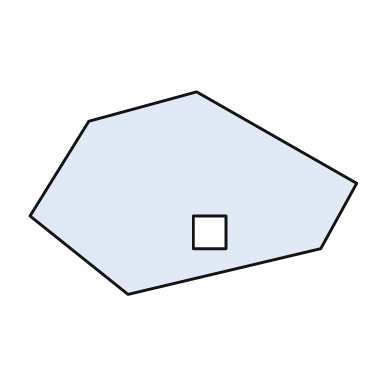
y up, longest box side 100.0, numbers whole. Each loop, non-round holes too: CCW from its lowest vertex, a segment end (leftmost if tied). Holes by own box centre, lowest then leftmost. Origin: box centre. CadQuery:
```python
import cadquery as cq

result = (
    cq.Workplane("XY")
    .moveTo(-20.0, -31.0)
    .lineTo(39.0, -17.0)
    .lineTo(50.0, 3.0)
    .lineTo(1.0, 31.0)
    .lineTo(-32.0, 22.0)
    .lineTo(-50.0, -7.0)
    .close()
    .moveTo(0.0, -17.0)
    .lineTo(10.0, -17.0)
    .lineTo(10.0, -7.0)
    .lineTo(0.0, -7.0)
    .close()
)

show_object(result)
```